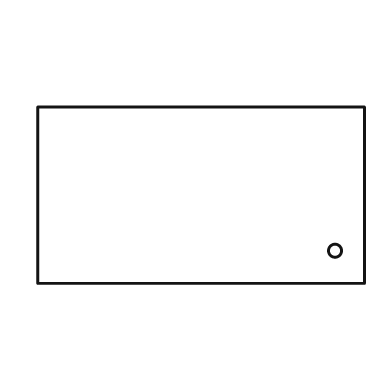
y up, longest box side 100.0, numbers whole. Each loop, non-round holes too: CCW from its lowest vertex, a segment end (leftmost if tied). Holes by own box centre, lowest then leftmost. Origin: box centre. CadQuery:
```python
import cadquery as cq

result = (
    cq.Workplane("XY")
    .moveTo(-50.0, -27.0)
    .lineTo(50.0, -27.0)
    .lineTo(50.0, 27.0)
    .lineTo(-50.0, 27.0)
    .close()
    .moveTo(41.0, -17.0)
    .circle(2.0)
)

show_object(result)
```